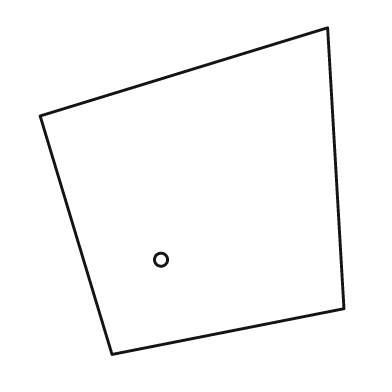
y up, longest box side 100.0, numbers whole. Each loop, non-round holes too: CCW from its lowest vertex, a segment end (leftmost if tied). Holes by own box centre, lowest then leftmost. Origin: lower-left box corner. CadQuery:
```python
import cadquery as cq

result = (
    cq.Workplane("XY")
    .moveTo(22.0, 0.0)
    .lineTo(93.0, 14.0)
    .lineTo(88.0, 100.0)
    .lineTo(0.0, 73.0)
    .close()
    .moveTo(37.0, 29.0)
    .circle(2.0)
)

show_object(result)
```